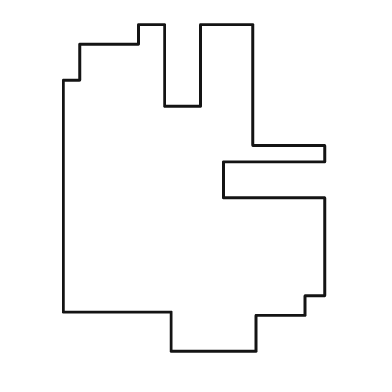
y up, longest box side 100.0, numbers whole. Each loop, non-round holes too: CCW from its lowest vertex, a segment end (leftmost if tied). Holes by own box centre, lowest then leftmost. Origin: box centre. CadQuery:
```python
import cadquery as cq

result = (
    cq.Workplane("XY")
    .moveTo(-7.0, -50.0)
    .lineTo(19.0, -50.0)
    .lineTo(19.0, -39.0)
    .lineTo(34.0, -39.0)
    .lineTo(34.0, -33.0)
    .lineTo(40.0, -33.0)
    .lineTo(40.0, -3.0)
    .lineTo(9.0, -3.0)
    .lineTo(9.0, 8.0)
    .lineTo(40.0, 8.0)
    .lineTo(40.0, 13.0)
    .lineTo(18.0, 13.0)
    .lineTo(18.0, 50.0)
    .lineTo(2.0, 50.0)
    .lineTo(2.0, 25.0)
    .lineTo(-9.0, 25.0)
    .lineTo(-9.0, 50.0)
    .lineTo(-17.0, 50.0)
    .lineTo(-17.0, 44.0)
    .lineTo(-35.0, 44.0)
    .lineTo(-35.0, 33.0)
    .lineTo(-40.0, 33.0)
    .lineTo(-40.0, -38.0)
    .lineTo(-7.0, -38.0)
    .close()
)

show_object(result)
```